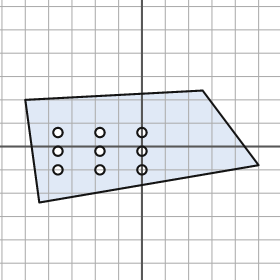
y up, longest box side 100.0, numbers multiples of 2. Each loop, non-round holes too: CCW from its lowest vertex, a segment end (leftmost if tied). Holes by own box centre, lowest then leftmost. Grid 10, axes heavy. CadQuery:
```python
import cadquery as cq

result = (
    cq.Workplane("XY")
    .moveTo(-44.0, -24.0)
    .lineTo(50.0, -8.0)
    .lineTo(26.0, 24.0)
    .lineTo(-50.0, 20.0)
    .close()
    .moveTo(-36.0, -10.0)
    .circle(2.0)
    .moveTo(-18.0, -10.0)
    .circle(2.0)
    .moveTo(0.0, -10.0)
    .circle(2.0)
    .moveTo(-36.0, -2.0)
    .circle(2.0)
    .moveTo(-18.0, -2.0)
    .circle(2.0)
    .moveTo(0.0, -2.0)
    .circle(2.0)
    .moveTo(-36.0, 6.0)
    .circle(2.0)
    .moveTo(-18.0, 6.0)
    .circle(2.0)
    .moveTo(0.0, 6.0)
    .circle(2.0)
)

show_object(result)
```